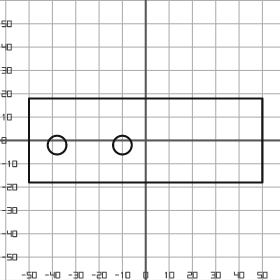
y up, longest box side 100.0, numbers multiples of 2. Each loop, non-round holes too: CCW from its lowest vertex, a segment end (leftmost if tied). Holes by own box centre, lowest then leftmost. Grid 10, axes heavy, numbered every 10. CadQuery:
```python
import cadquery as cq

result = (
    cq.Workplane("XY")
    .moveTo(-50.0, -18.0)
    .lineTo(50.0, -18.0)
    .lineTo(50.0, 18.0)
    .lineTo(-50.0, 18.0)
    .close()
    .moveTo(-38.0, -2.0)
    .circle(4.0)
    .moveTo(-10.0, -2.0)
    .circle(4.0)
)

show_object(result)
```